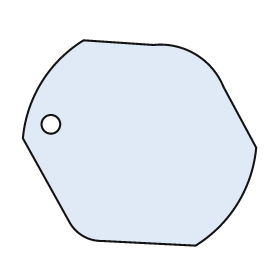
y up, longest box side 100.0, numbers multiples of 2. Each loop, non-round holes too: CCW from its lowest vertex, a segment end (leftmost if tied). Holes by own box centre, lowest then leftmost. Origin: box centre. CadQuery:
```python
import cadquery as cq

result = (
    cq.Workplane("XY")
    .moveTo(24.0, -44.0)
    .threePointArc((42.0, -26.0), (50.0, -2.0))
    .lineTo(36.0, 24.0)
    .threePointArc((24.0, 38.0), (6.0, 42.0))
    .lineTo(-24.0, 44.0)
    .threePointArc((-42.0, 26.0), (-50.0, 2.0))
    .lineTo(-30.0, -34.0)
    .threePointArc((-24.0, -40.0), (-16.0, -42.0))
    .close()
    .moveTo(-38.0, 8.0)
    .circle(4.0)
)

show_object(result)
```